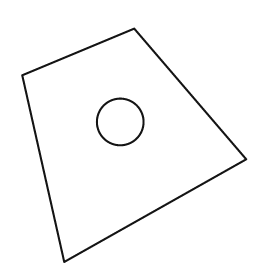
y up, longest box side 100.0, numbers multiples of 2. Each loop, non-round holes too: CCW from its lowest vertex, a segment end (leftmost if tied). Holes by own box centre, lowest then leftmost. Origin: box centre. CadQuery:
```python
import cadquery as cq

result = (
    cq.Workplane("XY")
    .moveTo(-30.0, -50.0)
    .lineTo(48.0, -6.0)
    .lineTo(0.0, 50.0)
    .lineTo(-48.0, 30.0)
    .close()
    .moveTo(-6.0, 10.0)
    .circle(10.0)
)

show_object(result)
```